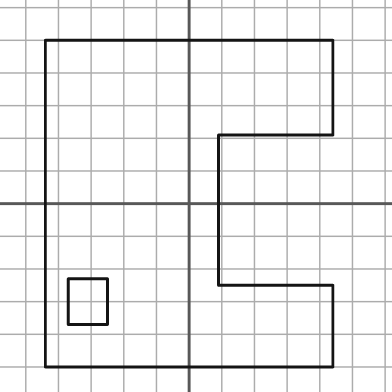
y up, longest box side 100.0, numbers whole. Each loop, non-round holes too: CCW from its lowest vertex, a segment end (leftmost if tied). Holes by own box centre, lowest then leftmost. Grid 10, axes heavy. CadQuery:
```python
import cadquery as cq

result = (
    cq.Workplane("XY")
    .moveTo(-44.0, -50.0)
    .lineTo(44.0, -50.0)
    .lineTo(44.0, -25.0)
    .lineTo(9.0, -25.0)
    .lineTo(9.0, 21.0)
    .lineTo(44.0, 21.0)
    .lineTo(44.0, 50.0)
    .lineTo(-44.0, 50.0)
    .close()
    .moveTo(-37.0, -37.0)
    .lineTo(-25.0, -37.0)
    .lineTo(-25.0, -23.0)
    .lineTo(-37.0, -23.0)
    .close()
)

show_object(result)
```